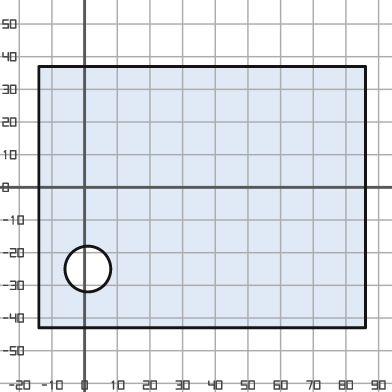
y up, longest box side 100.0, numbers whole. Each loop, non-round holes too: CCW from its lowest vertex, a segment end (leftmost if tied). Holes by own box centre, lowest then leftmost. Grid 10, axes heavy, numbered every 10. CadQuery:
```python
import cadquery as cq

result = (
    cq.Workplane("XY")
    .moveTo(-14.0, -43.0)
    .lineTo(86.0, -43.0)
    .lineTo(86.0, 37.0)
    .lineTo(-14.0, 37.0)
    .close()
    .moveTo(1.0, -25.0)
    .circle(7.0)
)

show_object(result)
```